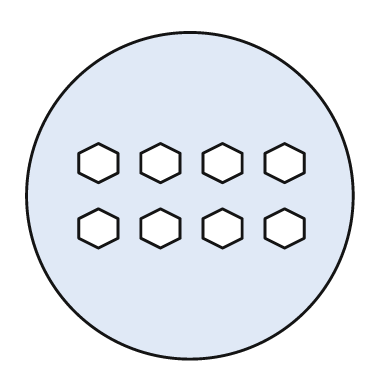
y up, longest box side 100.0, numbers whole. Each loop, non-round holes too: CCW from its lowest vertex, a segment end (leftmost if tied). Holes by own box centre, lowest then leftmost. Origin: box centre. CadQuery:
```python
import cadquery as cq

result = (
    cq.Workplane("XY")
    .moveTo(0.0, 0.0)
    .circle(50.0)
    .moveTo(-28.0, -16.0)
    .lineTo(-22.0, -13.0)
    .lineTo(-22.0, -7.0)
    .lineTo(-28.0, -4.0)
    .lineTo(-34.0, -7.0)
    .lineTo(-34.0, -13.0)
    .close()
    .moveTo(-9.0, -16.0)
    .lineTo(-3.0, -13.0)
    .lineTo(-3.0, -7.0)
    .lineTo(-9.0, -4.0)
    .lineTo(-15.0, -7.0)
    .lineTo(-15.0, -13.0)
    .close()
    .moveTo(10.0, -16.0)
    .lineTo(16.0, -13.0)
    .lineTo(16.0, -7.0)
    .lineTo(10.0, -4.0)
    .lineTo(4.0, -7.0)
    .lineTo(4.0, -13.0)
    .close()
    .moveTo(29.0, -16.0)
    .lineTo(35.0, -13.0)
    .lineTo(35.0, -7.0)
    .lineTo(29.0, -4.0)
    .lineTo(23.0, -7.0)
    .lineTo(23.0, -13.0)
    .close()
    .moveTo(-28.0, 4.0)
    .lineTo(-22.0, 7.0)
    .lineTo(-22.0, 13.0)
    .lineTo(-28.0, 16.0)
    .lineTo(-34.0, 13.0)
    .lineTo(-34.0, 7.0)
    .close()
    .moveTo(-9.0, 4.0)
    .lineTo(-3.0, 7.0)
    .lineTo(-3.0, 13.0)
    .lineTo(-9.0, 16.0)
    .lineTo(-15.0, 13.0)
    .lineTo(-15.0, 7.0)
    .close()
    .moveTo(10.0, 4.0)
    .lineTo(16.0, 7.0)
    .lineTo(16.0, 13.0)
    .lineTo(10.0, 16.0)
    .lineTo(4.0, 13.0)
    .lineTo(4.0, 7.0)
    .close()
    .moveTo(29.0, 4.0)
    .lineTo(35.0, 7.0)
    .lineTo(35.0, 13.0)
    .lineTo(29.0, 16.0)
    .lineTo(23.0, 13.0)
    .lineTo(23.0, 7.0)
    .close()
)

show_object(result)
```